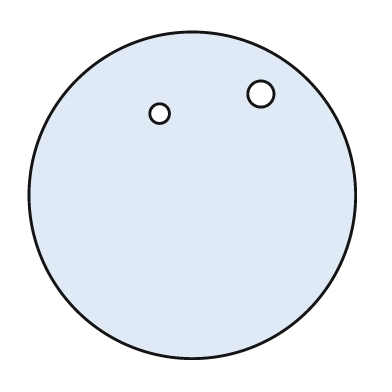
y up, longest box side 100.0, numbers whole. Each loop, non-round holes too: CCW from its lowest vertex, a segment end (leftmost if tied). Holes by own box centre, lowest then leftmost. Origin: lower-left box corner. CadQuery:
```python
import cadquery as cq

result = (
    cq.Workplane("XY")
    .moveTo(50.0, 50.0)
    .circle(50.0)
    .moveTo(40.0, 75.0)
    .circle(3.0)
    .moveTo(71.0, 81.0)
    .circle(4.0)
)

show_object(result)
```